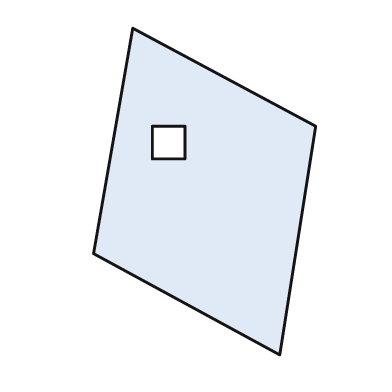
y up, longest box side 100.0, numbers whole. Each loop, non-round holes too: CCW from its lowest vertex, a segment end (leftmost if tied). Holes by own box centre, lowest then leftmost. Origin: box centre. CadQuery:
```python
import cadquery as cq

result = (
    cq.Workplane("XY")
    .moveTo(23.0, -50.0)
    .lineTo(34.0, 20.0)
    .lineTo(-22.0, 50.0)
    .lineTo(-34.0, -19.0)
    .close()
    .moveTo(-16.0, 10.0)
    .lineTo(-6.0, 10.0)
    .lineTo(-6.0, 20.0)
    .lineTo(-16.0, 20.0)
    .close()
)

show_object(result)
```